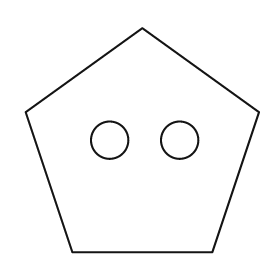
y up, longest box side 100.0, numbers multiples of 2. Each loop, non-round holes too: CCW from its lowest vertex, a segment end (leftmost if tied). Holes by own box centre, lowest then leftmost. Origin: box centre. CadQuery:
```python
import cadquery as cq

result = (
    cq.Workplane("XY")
    .moveTo(-30.0, -48.0)
    .lineTo(30.0, -48.0)
    .lineTo(50.0, 12.0)
    .lineTo(0.0, 48.0)
    .lineTo(-50.0, 12.0)
    .close()
    .moveTo(-14.0, 0.0)
    .circle(8.0)
    .moveTo(16.0, 0.0)
    .circle(8.0)
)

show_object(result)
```